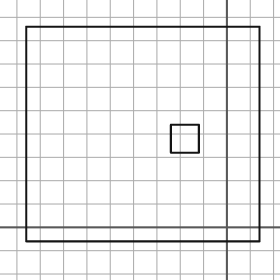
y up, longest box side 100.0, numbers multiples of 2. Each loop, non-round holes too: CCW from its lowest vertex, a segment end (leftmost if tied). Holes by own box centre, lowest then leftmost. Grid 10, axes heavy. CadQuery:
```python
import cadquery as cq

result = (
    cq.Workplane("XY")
    .moveTo(-86.0, -6.0)
    .lineTo(14.0, -6.0)
    .lineTo(14.0, 86.0)
    .lineTo(-86.0, 86.0)
    .close()
    .moveTo(-24.0, 32.0)
    .lineTo(-12.0, 32.0)
    .lineTo(-12.0, 44.0)
    .lineTo(-24.0, 44.0)
    .close()
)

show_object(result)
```